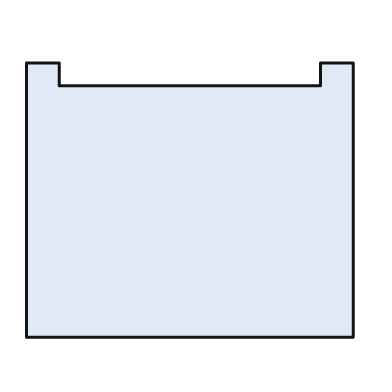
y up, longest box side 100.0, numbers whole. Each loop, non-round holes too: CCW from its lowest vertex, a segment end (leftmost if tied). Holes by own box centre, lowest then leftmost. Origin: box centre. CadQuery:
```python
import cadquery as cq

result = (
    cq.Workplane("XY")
    .moveTo(-50.0, -42.0)
    .lineTo(50.0, -42.0)
    .lineTo(50.0, 42.0)
    .lineTo(40.0, 42.0)
    .lineTo(40.0, 35.0)
    .lineTo(-40.0, 35.0)
    .lineTo(-40.0, 42.0)
    .lineTo(-50.0, 42.0)
    .close()
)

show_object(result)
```